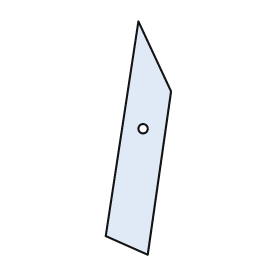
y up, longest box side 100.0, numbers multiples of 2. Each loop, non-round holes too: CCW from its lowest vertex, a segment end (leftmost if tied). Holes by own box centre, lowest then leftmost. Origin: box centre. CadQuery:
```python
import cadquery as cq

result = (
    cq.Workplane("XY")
    .moveTo(4.0, -50.0)
    .lineTo(14.0, 20.0)
    .lineTo(0.0, 50.0)
    .lineTo(-14.0, -42.0)
    .close()
    .moveTo(2.0, 4.0)
    .circle(2.0)
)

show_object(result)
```